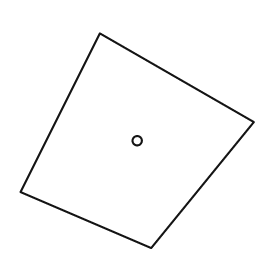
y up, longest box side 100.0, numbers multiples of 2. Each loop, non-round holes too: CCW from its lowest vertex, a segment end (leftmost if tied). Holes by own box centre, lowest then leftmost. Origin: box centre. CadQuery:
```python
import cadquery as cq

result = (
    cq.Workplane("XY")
    .moveTo(6.0, -46.0)
    .lineTo(50.0, 8.0)
    .lineTo(-16.0, 46.0)
    .lineTo(-50.0, -22.0)
    .close()
    .moveTo(0.0, 0.0)
    .circle(2.0)
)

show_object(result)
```